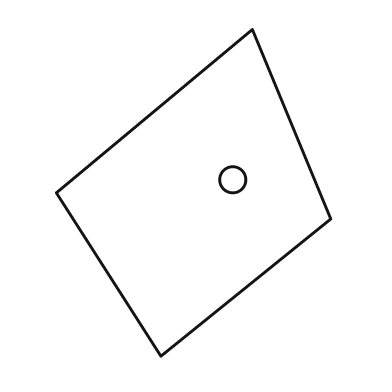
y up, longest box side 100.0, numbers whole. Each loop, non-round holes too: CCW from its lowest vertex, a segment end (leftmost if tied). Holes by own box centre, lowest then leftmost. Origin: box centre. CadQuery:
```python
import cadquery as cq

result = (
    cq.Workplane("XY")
    .moveTo(-10.0, -50.0)
    .lineTo(42.0, -8.0)
    .lineTo(18.0, 50.0)
    .lineTo(-42.0, 0.0)
    .close()
    .moveTo(12.0, 4.0)
    .circle(4.0)
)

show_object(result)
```